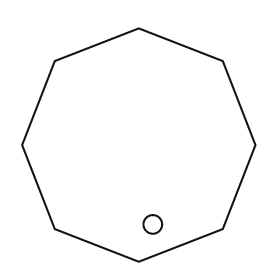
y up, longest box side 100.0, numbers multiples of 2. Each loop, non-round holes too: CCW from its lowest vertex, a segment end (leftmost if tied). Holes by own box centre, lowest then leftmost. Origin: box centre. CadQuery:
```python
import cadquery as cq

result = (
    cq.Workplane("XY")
    .moveTo(0.0, -50.0)
    .lineTo(36.0, -36.0)
    .lineTo(50.0, 0.0)
    .lineTo(36.0, 36.0)
    .lineTo(0.0, 50.0)
    .lineTo(-36.0, 36.0)
    .lineTo(-50.0, 0.0)
    .lineTo(-36.0, -36.0)
    .close()
    .moveTo(6.0, -34.0)
    .circle(4.0)
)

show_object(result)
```